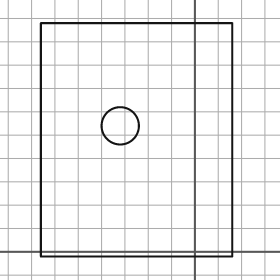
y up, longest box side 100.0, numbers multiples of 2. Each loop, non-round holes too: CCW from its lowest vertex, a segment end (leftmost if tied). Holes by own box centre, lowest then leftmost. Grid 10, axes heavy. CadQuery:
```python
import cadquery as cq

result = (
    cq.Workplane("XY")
    .moveTo(-66.0, -2.0)
    .lineTo(16.0, -2.0)
    .lineTo(16.0, 98.0)
    .lineTo(-66.0, 98.0)
    .close()
    .moveTo(-32.0, 54.0)
    .circle(8.0)
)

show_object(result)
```